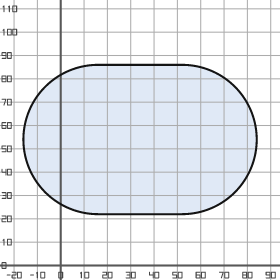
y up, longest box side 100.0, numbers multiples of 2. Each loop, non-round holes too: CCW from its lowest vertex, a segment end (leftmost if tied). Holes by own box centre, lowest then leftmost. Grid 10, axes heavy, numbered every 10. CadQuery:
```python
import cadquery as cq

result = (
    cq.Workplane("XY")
    .moveTo(16.0, 22.0)
    .lineTo(52.0, 22.0)
    .threePointArc((84.0, 54.0), (52.0, 86.0))
    .lineTo(16.0, 86.0)
    .threePointArc((-16.0, 54.0), (16.0, 22.0))
    .close()
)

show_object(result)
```